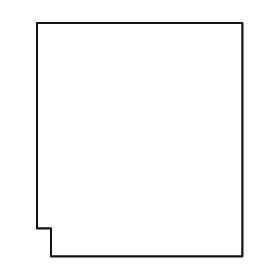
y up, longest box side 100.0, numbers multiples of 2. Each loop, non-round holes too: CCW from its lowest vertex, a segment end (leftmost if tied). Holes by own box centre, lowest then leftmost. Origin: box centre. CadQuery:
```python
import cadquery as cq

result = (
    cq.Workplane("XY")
    .moveTo(-38.0, -50.0)
    .lineTo(44.0, -50.0)
    .lineTo(44.0, 50.0)
    .lineTo(-44.0, 50.0)
    .lineTo(-44.0, -38.0)
    .lineTo(-38.0, -38.0)
    .close()
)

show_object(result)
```